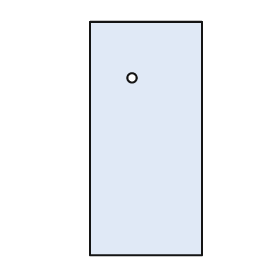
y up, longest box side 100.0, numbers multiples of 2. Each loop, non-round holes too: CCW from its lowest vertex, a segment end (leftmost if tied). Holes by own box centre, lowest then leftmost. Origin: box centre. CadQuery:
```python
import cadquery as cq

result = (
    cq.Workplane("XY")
    .moveTo(-24.0, -50.0)
    .lineTo(24.0, -50.0)
    .lineTo(24.0, 50.0)
    .lineTo(-24.0, 50.0)
    .close()
    .moveTo(-6.0, 26.0)
    .circle(2.0)
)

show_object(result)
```